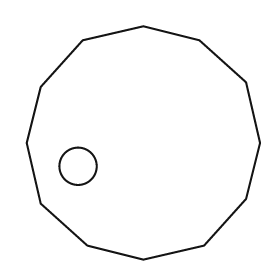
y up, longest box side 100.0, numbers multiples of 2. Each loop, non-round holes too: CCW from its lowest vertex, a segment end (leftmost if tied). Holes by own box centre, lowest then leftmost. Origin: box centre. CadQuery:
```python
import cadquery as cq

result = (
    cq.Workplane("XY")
    .moveTo(0.0, -50.0)
    .lineTo(26.0, -44.0)
    .lineTo(44.0, -24.0)
    .lineTo(50.0, 0.0)
    .lineTo(44.0, 26.0)
    .lineTo(24.0, 44.0)
    .lineTo(0.0, 50.0)
    .lineTo(-26.0, 44.0)
    .lineTo(-44.0, 24.0)
    .lineTo(-50.0, 0.0)
    .lineTo(-44.0, -26.0)
    .lineTo(-24.0, -44.0)
    .close()
    .moveTo(-28.0, -10.0)
    .circle(8.0)
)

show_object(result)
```